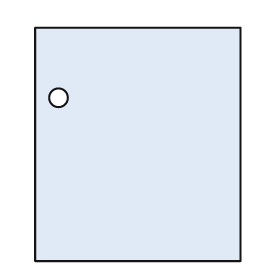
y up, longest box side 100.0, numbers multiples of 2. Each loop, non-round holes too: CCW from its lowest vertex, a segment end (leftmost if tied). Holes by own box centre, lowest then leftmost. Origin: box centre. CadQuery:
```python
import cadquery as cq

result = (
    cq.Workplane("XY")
    .moveTo(-44.0, -50.0)
    .lineTo(44.0, -50.0)
    .lineTo(44.0, 50.0)
    .lineTo(-44.0, 50.0)
    .close()
    .moveTo(-34.0, 20.0)
    .circle(4.0)
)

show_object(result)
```